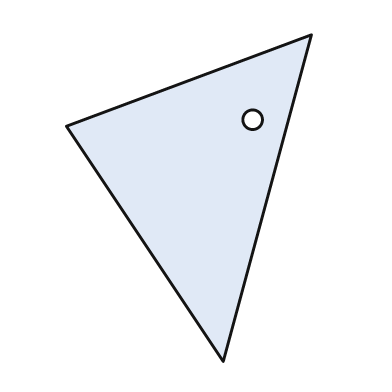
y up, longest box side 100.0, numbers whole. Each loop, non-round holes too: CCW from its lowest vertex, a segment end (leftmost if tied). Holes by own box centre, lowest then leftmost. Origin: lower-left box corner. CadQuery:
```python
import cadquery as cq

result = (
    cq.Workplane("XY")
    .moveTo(48.0, 0.0)
    .lineTo(75.0, 100.0)
    .lineTo(0.0, 72.0)
    .close()
    .moveTo(57.0, 74.0)
    .circle(3.0)
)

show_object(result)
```